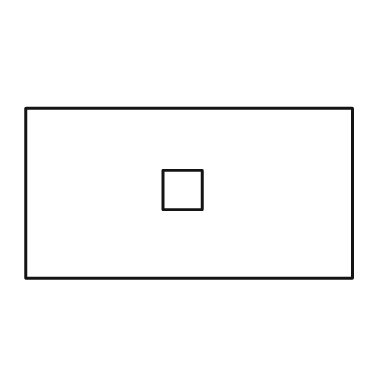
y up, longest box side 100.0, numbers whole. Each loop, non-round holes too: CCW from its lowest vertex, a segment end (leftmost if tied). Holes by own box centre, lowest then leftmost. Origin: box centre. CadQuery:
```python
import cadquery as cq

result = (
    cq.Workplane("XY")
    .moveTo(-50.0, -26.0)
    .lineTo(50.0, -26.0)
    .lineTo(50.0, 26.0)
    .lineTo(-50.0, 26.0)
    .close()
    .moveTo(-8.0, -5.0)
    .lineTo(4.0, -5.0)
    .lineTo(4.0, 7.0)
    .lineTo(-8.0, 7.0)
    .close()
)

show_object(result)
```